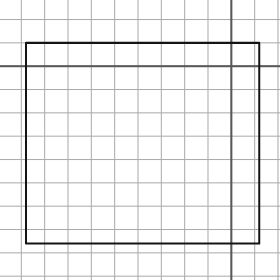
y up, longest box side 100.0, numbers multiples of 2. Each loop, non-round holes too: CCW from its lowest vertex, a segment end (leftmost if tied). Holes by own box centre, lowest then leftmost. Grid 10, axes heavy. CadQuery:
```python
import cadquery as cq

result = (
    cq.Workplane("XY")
    .moveTo(-88.0, -76.0)
    .lineTo(12.0, -76.0)
    .lineTo(12.0, 10.0)
    .lineTo(-88.0, 10.0)
    .close()
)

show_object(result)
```